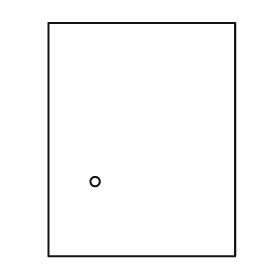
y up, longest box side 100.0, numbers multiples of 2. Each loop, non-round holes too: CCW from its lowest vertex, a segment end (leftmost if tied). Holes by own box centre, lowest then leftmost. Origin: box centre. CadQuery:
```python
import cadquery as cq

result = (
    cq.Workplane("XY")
    .moveTo(-40.0, -50.0)
    .lineTo(40.0, -50.0)
    .lineTo(40.0, 50.0)
    .lineTo(-40.0, 50.0)
    .close()
    .moveTo(-20.0, -18.0)
    .circle(2.0)
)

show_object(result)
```